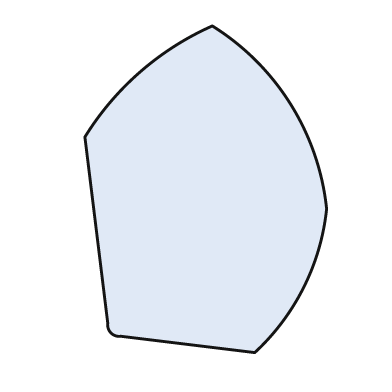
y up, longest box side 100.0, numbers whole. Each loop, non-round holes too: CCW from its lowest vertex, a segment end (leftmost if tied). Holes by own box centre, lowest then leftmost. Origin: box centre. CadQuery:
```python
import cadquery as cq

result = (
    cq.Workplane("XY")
    .moveTo(15.0, -50.0)
    .threePointArc((30.0, -30.0), (37.0, -6.0))
    .threePointArc((26.0, 26.0), (2.0, 50.0))
    .threePointArc((-20.0, 36.0), (-37.0, 16.0))
    .lineTo(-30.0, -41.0)
    .threePointArc((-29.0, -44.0), (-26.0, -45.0))
    .close()
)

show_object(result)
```